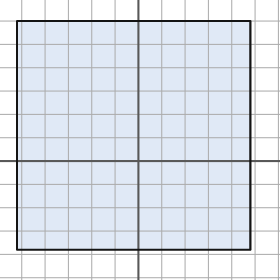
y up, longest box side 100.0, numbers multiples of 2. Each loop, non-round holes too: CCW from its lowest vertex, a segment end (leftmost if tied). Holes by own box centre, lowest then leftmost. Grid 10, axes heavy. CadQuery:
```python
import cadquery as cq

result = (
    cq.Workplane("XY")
    .moveTo(-52.0, -38.0)
    .lineTo(48.0, -38.0)
    .lineTo(48.0, 60.0)
    .lineTo(-52.0, 60.0)
    .close()
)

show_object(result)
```